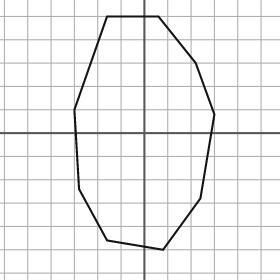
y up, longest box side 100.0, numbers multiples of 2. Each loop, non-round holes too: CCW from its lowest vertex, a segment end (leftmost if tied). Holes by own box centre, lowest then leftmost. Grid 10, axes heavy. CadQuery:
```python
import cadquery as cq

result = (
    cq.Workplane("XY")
    .moveTo(8.0, -50.0)
    .lineTo(24.0, -28.0)
    .lineTo(30.0, 8.0)
    .lineTo(22.0, 30.0)
    .lineTo(6.0, 50.0)
    .lineTo(-16.0, 50.0)
    .lineTo(-30.0, 10.0)
    .lineTo(-28.0, -24.0)
    .lineTo(-16.0, -46.0)
    .close()
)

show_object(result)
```